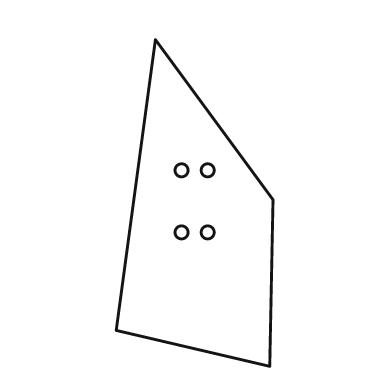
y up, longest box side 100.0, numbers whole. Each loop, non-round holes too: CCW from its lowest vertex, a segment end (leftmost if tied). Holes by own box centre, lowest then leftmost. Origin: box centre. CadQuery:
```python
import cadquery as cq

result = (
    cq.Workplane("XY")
    .moveTo(23.0, -50.0)
    .lineTo(24.0, 1.0)
    .lineTo(-12.0, 50.0)
    .lineTo(-24.0, -39.0)
    .close()
    .moveTo(-4.0, -9.0)
    .circle(2.0)
    .moveTo(4.0, -9.0)
    .circle(2.0)
    .moveTo(-4.0, 10.0)
    .circle(2.0)
    .moveTo(4.0, 10.0)
    .circle(2.0)
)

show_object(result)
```